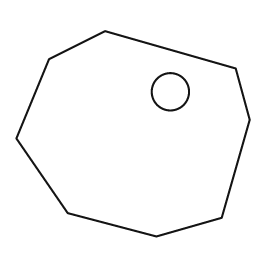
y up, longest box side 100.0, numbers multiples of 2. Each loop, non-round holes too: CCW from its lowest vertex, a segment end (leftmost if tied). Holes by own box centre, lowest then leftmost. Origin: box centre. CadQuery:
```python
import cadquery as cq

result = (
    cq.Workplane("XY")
    .moveTo(10.0, -44.0)
    .lineTo(38.0, -36.0)
    .lineTo(50.0, 6.0)
    .lineTo(44.0, 28.0)
    .lineTo(-12.0, 44.0)
    .lineTo(-36.0, 32.0)
    .lineTo(-50.0, -2.0)
    .lineTo(-28.0, -34.0)
    .close()
    .moveTo(16.0, 18.0)
    .circle(8.0)
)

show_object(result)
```